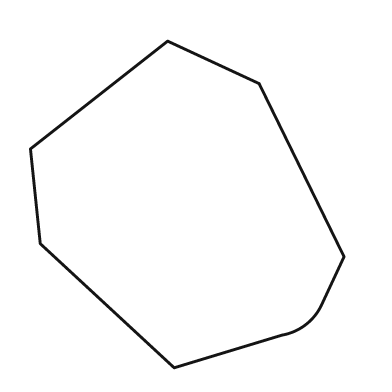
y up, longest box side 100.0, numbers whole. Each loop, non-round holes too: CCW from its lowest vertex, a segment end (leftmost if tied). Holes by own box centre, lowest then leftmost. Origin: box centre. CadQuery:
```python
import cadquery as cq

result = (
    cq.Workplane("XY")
    .moveTo(-4.0, -50.0)
    .lineTo(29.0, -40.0)
    .threePointArc((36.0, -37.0), (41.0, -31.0))
    .lineTo(48.0, -16.0)
    .lineTo(22.0, 37.0)
    .lineTo(-6.0, 50.0)
    .lineTo(-48.0, 17.0)
    .lineTo(-45.0, -12.0)
    .close()
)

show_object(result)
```